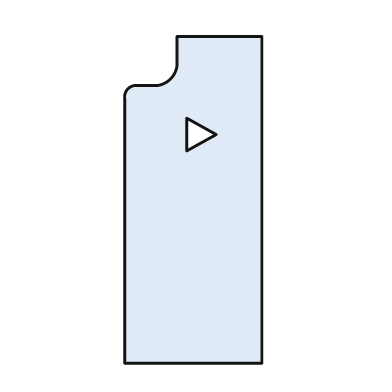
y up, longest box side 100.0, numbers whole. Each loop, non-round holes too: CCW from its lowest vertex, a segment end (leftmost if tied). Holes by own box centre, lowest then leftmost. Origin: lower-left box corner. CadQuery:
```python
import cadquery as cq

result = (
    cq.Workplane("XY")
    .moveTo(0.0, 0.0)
    .lineTo(42.0, 0.0)
    .lineTo(42.0, 100.0)
    .lineTo(16.0, 100.0)
    .lineTo(16.0, 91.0)
    .threePointArc((14.0, 87.0), (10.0, 85.0))
    .lineTo(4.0, 85.0)
    .threePointArc((1.0, 84.0), (0.0, 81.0))
    .close()
    .moveTo(19.0, 65.0)
    .lineTo(28.0, 70.0)
    .lineTo(19.0, 75.0)
    .close()
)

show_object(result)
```